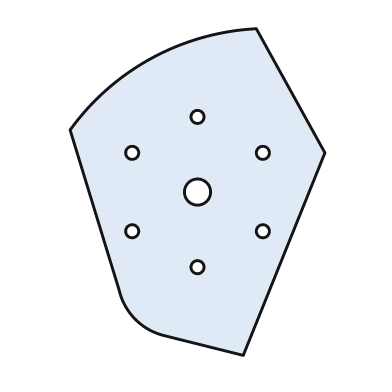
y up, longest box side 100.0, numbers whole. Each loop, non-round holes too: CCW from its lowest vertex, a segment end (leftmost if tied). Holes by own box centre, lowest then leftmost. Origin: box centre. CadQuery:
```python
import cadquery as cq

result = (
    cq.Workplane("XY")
    .moveTo(14.0, -50.0)
    .lineTo(39.0, 12.0)
    .lineTo(18.0, 50.0)
    .threePointArc((-14.0, 41.0), (-39.0, 19.0))
    .lineTo(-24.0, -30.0)
    .threePointArc((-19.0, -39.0), (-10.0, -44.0))
    .close()
    .moveTo(0.0, -23.0)
    .circle(2.0)
    .moveTo(-20.0, -12.0)
    .circle(2.0)
    .moveTo(20.0, -12.0)
    .circle(2.0)
    .moveTo(0.0, 0.0)
    .circle(4.0)
    .moveTo(-20.0, 12.0)
    .circle(2.0)
    .moveTo(20.0, 12.0)
    .circle(2.0)
    .moveTo(0.0, 23.0)
    .circle(2.0)
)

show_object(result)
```